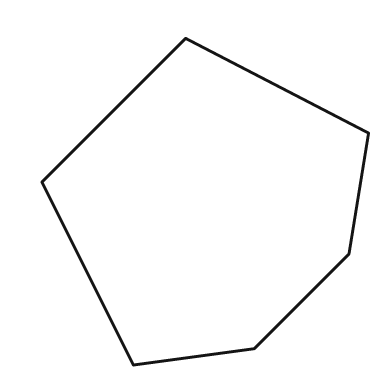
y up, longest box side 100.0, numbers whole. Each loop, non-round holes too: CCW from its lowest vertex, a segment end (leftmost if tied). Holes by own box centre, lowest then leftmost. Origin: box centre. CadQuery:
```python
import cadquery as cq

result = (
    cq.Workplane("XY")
    .moveTo(-22.0, -50.0)
    .lineTo(15.0, -45.0)
    .lineTo(44.0, -16.0)
    .lineTo(50.0, 21.0)
    .lineTo(-6.0, 50.0)
    .lineTo(-50.0, 6.0)
    .close()
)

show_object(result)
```